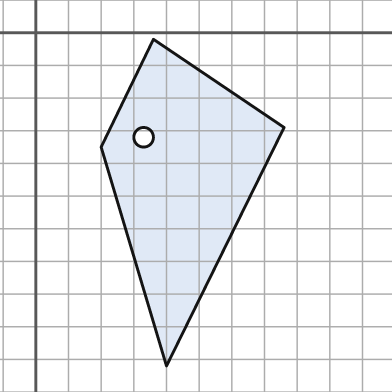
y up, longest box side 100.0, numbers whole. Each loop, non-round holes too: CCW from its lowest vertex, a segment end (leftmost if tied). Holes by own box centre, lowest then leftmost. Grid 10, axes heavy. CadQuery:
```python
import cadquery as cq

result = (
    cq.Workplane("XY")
    .moveTo(40.0, -102.0)
    .lineTo(76.0, -29.0)
    .lineTo(36.0, -2.0)
    .lineTo(20.0, -35.0)
    .close()
    .moveTo(33.0, -32.0)
    .circle(3.0)
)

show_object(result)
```